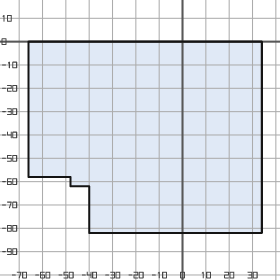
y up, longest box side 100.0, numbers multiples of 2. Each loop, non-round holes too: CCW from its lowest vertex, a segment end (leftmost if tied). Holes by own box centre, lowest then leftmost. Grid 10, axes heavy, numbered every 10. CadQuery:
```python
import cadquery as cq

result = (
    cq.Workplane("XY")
    .moveTo(-40.0, -82.0)
    .lineTo(34.0, -82.0)
    .lineTo(34.0, 0.0)
    .lineTo(-66.0, 0.0)
    .lineTo(-66.0, -58.0)
    .lineTo(-48.0, -58.0)
    .lineTo(-48.0, -62.0)
    .lineTo(-40.0, -62.0)
    .close()
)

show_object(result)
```